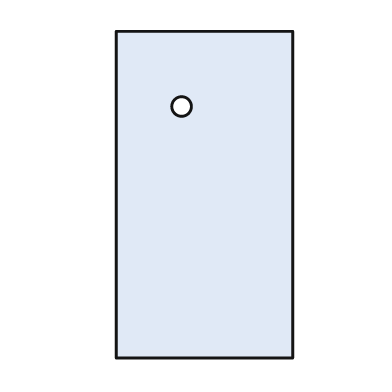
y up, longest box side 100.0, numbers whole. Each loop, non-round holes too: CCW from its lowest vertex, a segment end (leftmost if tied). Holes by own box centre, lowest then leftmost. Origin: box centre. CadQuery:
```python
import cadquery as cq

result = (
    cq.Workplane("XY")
    .moveTo(-27.0, -50.0)
    .lineTo(27.0, -50.0)
    .lineTo(27.0, 50.0)
    .lineTo(-27.0, 50.0)
    .close()
    .moveTo(-7.0, 27.0)
    .circle(3.0)
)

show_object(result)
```